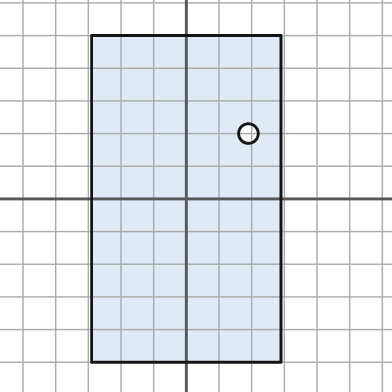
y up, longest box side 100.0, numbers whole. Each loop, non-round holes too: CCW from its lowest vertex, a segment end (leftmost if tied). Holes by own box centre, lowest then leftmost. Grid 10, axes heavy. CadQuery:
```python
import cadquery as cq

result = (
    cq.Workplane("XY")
    .moveTo(-29.0, -50.0)
    .lineTo(29.0, -50.0)
    .lineTo(29.0, 50.0)
    .lineTo(-29.0, 50.0)
    .close()
    .moveTo(19.0, 20.0)
    .circle(3.0)
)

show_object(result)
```